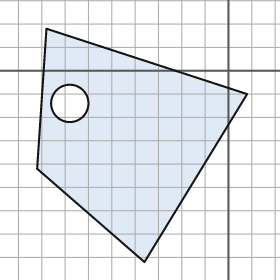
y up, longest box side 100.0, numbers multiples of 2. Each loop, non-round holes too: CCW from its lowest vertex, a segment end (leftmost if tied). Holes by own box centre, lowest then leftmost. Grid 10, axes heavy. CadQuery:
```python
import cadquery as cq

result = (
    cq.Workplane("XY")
    .moveTo(-36.0, -82.0)
    .lineTo(8.0, -10.0)
    .lineTo(-78.0, 18.0)
    .lineTo(-82.0, -42.0)
    .close()
    .moveTo(-68.0, -14.0)
    .circle(8.0)
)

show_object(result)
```